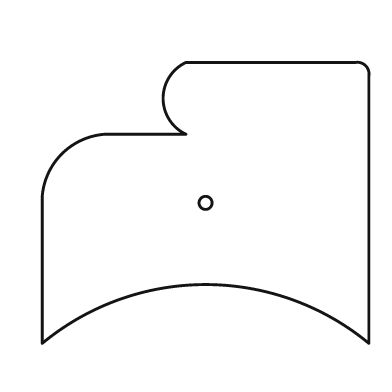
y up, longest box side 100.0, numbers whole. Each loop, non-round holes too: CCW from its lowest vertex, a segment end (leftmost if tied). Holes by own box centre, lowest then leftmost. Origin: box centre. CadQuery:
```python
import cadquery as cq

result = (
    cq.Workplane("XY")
    .moveTo(-50.0, -43.0)
    .threePointArc((0.0, -25.0), (50.0, -43.0))
    .lineTo(50.0, 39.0)
    .threePointArc((49.0, 42.0), (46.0, 43.0))
    .lineTo(-6.0, 43.0)
    .threePointArc((-13.0, 32.0), (-6.0, 21.0))
    .lineTo(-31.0, 21.0)
    .threePointArc((-44.0, 15.0), (-50.0, 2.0))
    .close()
    .moveTo(0.0, 0.0)
    .circle(2.0)
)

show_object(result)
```